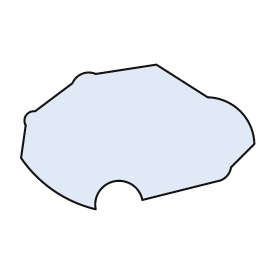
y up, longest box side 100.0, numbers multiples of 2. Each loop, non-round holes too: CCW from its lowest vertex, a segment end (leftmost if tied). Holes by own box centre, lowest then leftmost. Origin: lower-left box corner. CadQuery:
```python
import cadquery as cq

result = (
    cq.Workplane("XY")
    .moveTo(32.0, 0.0)
    .threePointArc((40.0, 12.0), (52.0, 4.0))
    .lineTo(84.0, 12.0)
    .threePointArc((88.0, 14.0), (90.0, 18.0))
    .lineTo(100.0, 28.0)
    .threePointArc((94.0, 42.0), (80.0, 48.0))
    .lineTo(58.0, 62.0)
    .lineTo(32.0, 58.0)
    .threePointArc((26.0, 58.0), (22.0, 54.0))
    .lineTo(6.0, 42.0)
    .threePointArc((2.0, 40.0), (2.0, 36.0))
    .lineTo(0.0, 22.0)
    .threePointArc((14.0, 8.0), (32.0, 0.0))
    .close()
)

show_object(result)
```